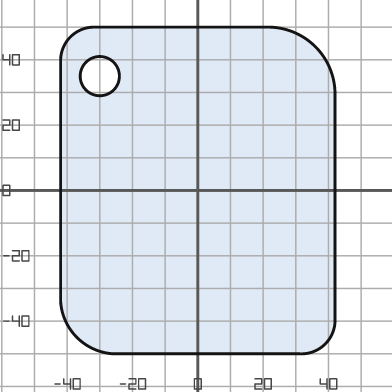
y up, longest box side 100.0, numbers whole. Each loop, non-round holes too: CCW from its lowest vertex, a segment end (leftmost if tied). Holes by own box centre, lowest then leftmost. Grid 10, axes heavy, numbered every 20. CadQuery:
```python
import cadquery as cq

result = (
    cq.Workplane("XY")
    .moveTo(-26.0, -50.0)
    .lineTo(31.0, -50.0)
    .threePointArc((39.0, -47.0), (42.0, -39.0))
    .lineTo(42.0, 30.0)
    .threePointArc((36.0, 44.0), (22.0, 50.0))
    .lineTo(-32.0, 50.0)
    .threePointArc((-39.0, 47.0), (-42.0, 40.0))
    .lineTo(-42.0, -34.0)
    .threePointArc((-37.0, -45.0), (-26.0, -50.0))
    .close()
    .moveTo(-30.0, 35.0)
    .circle(6.0)
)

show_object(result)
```